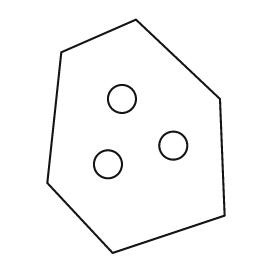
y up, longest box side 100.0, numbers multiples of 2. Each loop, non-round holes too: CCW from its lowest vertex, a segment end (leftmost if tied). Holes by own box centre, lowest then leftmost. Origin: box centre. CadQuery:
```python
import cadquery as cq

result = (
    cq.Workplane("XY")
    .moveTo(-10.0, -50.0)
    .lineTo(38.0, -34.0)
    .lineTo(36.0, 16.0)
    .lineTo(0.0, 50.0)
    .lineTo(-32.0, 36.0)
    .lineTo(-38.0, -20.0)
    .close()
    .moveTo(-12.0, -12.0)
    .circle(6.0)
    .moveTo(16.0, -4.0)
    .circle(6.0)
    .moveTo(-6.0, 16.0)
    .circle(6.0)
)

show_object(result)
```